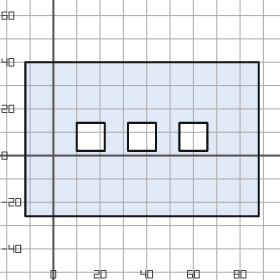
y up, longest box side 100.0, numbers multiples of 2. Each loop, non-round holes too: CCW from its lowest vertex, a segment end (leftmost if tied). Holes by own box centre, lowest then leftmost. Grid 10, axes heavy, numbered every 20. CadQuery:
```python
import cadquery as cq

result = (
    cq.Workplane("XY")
    .moveTo(-12.0, -26.0)
    .lineTo(88.0, -26.0)
    .lineTo(88.0, 40.0)
    .lineTo(-12.0, 40.0)
    .close()
    .moveTo(10.0, 2.0)
    .lineTo(22.0, 2.0)
    .lineTo(22.0, 14.0)
    .lineTo(10.0, 14.0)
    .close()
    .moveTo(32.0, 2.0)
    .lineTo(44.0, 2.0)
    .lineTo(44.0, 14.0)
    .lineTo(32.0, 14.0)
    .close()
    .moveTo(54.0, 2.0)
    .lineTo(66.0, 2.0)
    .lineTo(66.0, 14.0)
    .lineTo(54.0, 14.0)
    .close()
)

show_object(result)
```